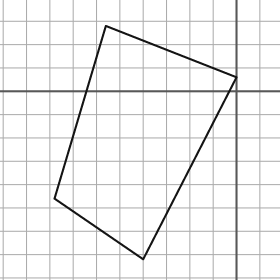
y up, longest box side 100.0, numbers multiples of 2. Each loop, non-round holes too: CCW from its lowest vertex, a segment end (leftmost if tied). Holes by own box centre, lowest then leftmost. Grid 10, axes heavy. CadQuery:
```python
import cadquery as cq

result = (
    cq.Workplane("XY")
    .moveTo(-40.0, -72.0)
    .lineTo(0.0, 6.0)
    .lineTo(-56.0, 28.0)
    .lineTo(-78.0, -46.0)
    .close()
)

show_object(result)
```